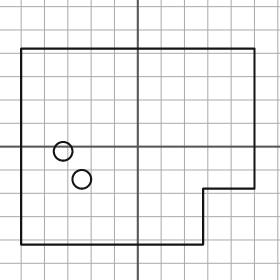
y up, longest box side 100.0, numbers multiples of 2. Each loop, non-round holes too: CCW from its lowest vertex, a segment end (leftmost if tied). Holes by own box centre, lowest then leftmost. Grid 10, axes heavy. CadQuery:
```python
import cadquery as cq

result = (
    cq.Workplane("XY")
    .moveTo(-50.0, -42.0)
    .lineTo(28.0, -42.0)
    .lineTo(28.0, -18.0)
    .lineTo(50.0, -18.0)
    .lineTo(50.0, 42.0)
    .lineTo(-50.0, 42.0)
    .close()
    .moveTo(-24.0, -14.0)
    .circle(4.0)
    .moveTo(-32.0, -2.0)
    .circle(4.0)
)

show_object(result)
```